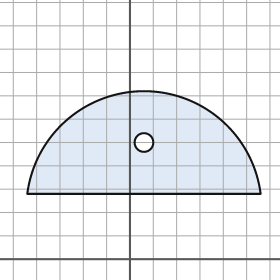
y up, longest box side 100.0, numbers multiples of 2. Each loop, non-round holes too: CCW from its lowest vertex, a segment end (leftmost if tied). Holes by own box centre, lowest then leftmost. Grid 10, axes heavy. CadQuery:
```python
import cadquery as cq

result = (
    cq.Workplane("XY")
    .moveTo(-44.0, 28.0)
    .lineTo(56.0, 28.0)
    .threePointArc((6.0, 72.0), (-44.0, 28.0))
    .close()
    .moveTo(6.0, 50.0)
    .circle(4.0)
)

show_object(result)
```